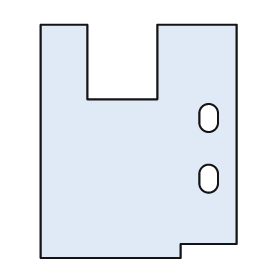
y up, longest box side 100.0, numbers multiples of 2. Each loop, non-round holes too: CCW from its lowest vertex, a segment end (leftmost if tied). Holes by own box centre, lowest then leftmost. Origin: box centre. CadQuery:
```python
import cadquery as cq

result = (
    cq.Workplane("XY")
    .moveTo(-42.0, -50.0)
    .lineTo(18.0, -50.0)
    .lineTo(18.0, -44.0)
    .lineTo(42.0, -44.0)
    .lineTo(42.0, 50.0)
    .lineTo(8.0, 50.0)
    .lineTo(8.0, 18.0)
    .lineTo(-22.0, 18.0)
    .lineTo(-22.0, 50.0)
    .lineTo(-42.0, 50.0)
    .close()
    .moveTo(26.0, -18.0)
    .threePointArc((30.0, -22.0), (34.0, -18.0))
    .lineTo(34.0, -14.0)
    .threePointArc((30.0, -10.0), (26.0, -14.0))
    .close()
    .moveTo(26.0, 8.0)
    .threePointArc((30.0, 4.0), (34.0, 8.0))
    .lineTo(34.0, 12.0)
    .threePointArc((30.0, 16.0), (26.0, 12.0))
    .close()
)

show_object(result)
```